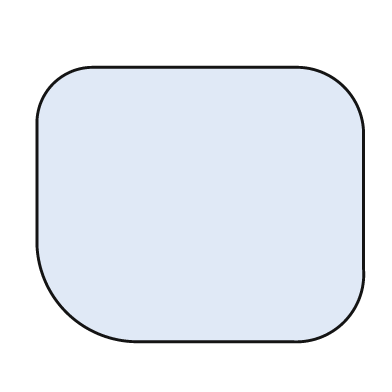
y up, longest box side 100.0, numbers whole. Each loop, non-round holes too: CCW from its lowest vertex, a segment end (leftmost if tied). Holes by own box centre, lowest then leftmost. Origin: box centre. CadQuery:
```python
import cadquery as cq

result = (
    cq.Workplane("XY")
    .moveTo(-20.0, -42.0)
    .lineTo(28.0, -42.0)
    .threePointArc((44.0, -36.0), (50.0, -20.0))
    .lineTo(50.0, 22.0)
    .threePointArc((44.0, 36.0), (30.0, 42.0))
    .lineTo(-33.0, 42.0)
    .threePointArc((-45.0, 37.0), (-50.0, 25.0))
    .lineTo(-50.0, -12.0)
    .threePointArc((-41.0, -33.0), (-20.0, -42.0))
    .close()
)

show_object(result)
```